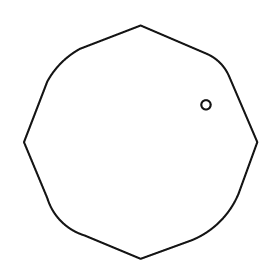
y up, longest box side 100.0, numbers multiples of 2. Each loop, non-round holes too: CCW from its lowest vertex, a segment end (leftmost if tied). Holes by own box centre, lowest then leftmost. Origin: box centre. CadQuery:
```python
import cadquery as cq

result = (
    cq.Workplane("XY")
    .moveTo(0.0, -50.0)
    .lineTo(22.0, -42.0)
    .threePointArc((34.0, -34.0), (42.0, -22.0))
    .lineTo(50.0, 0.0)
    .lineTo(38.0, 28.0)
    .threePointArc((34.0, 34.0), (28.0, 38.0))
    .lineTo(0.0, 50.0)
    .lineTo(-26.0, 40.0)
    .threePointArc((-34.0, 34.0), (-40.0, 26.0))
    .lineTo(-50.0, 0.0)
    .lineTo(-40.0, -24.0)
    .threePointArc((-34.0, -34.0), (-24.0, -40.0))
    .close()
    .moveTo(28.0, 16.0)
    .circle(2.0)
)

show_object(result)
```